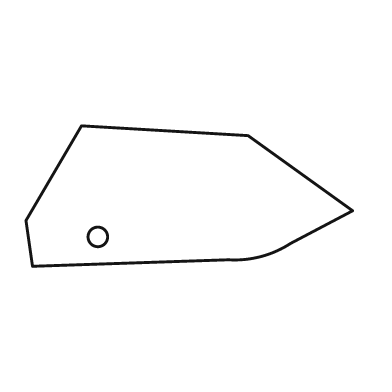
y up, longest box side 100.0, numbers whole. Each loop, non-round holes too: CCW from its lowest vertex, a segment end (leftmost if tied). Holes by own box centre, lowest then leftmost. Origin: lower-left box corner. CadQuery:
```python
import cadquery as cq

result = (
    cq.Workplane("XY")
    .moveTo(2.0, 0.0)
    .lineTo(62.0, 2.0)
    .threePointArc((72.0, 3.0), (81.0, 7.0))
    .lineTo(100.0, 17.0)
    .lineTo(68.0, 40.0)
    .lineTo(17.0, 43.0)
    .lineTo(0.0, 14.0)
    .close()
    .moveTo(22.0, 9.0)
    .circle(3.0)
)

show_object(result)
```